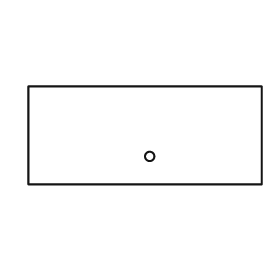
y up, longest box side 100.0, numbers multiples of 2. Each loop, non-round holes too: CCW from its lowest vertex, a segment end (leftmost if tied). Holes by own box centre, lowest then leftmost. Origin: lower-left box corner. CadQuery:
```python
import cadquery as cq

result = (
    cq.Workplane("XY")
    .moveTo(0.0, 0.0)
    .lineTo(100.0, 0.0)
    .lineTo(100.0, 42.0)
    .lineTo(0.0, 42.0)
    .close()
    .moveTo(52.0, 12.0)
    .circle(2.0)
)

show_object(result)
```